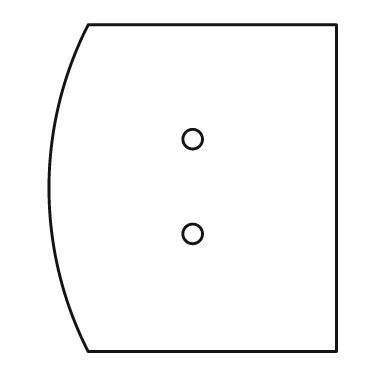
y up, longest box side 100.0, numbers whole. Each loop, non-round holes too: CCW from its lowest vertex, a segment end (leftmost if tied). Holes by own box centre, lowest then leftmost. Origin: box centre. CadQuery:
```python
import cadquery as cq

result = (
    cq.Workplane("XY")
    .moveTo(-32.0, -50.0)
    .lineTo(44.0, -50.0)
    .lineTo(44.0, 50.0)
    .lineTo(-32.0, 50.0)
    .threePointArc((-44.0, 0.0), (-32.0, -50.0))
    .close()
    .moveTo(0.0, -14.0)
    .circle(3.0)
    .moveTo(0.0, 15.0)
    .circle(3.0)
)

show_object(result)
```